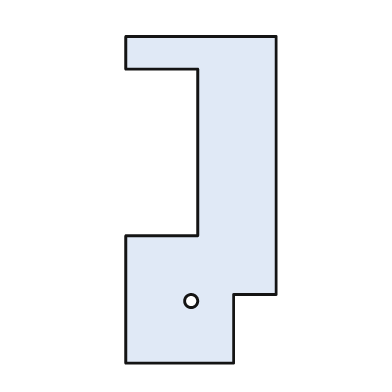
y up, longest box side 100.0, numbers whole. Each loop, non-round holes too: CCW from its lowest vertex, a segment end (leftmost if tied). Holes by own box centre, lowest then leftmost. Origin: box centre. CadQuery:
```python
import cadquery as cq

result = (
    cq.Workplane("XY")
    .moveTo(-23.0, -50.0)
    .lineTo(10.0, -50.0)
    .lineTo(10.0, -29.0)
    .lineTo(23.0, -29.0)
    .lineTo(23.0, 50.0)
    .lineTo(-23.0, 50.0)
    .lineTo(-23.0, 40.0)
    .lineTo(-1.0, 40.0)
    .lineTo(-1.0, -11.0)
    .lineTo(-23.0, -11.0)
    .close()
    .moveTo(-3.0, -31.0)
    .circle(2.0)
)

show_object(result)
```